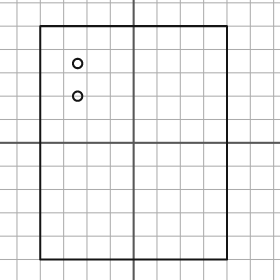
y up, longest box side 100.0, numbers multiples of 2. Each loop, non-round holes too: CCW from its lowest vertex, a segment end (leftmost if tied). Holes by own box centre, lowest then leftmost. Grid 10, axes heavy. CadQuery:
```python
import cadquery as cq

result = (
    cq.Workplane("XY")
    .moveTo(-40.0, -50.0)
    .lineTo(40.0, -50.0)
    .lineTo(40.0, 50.0)
    .lineTo(-40.0, 50.0)
    .close()
    .moveTo(-24.0, 20.0)
    .circle(2.0)
    .moveTo(-24.0, 34.0)
    .circle(2.0)
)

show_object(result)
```